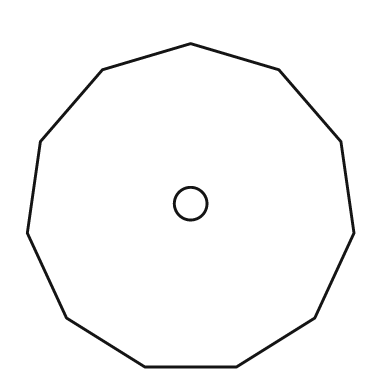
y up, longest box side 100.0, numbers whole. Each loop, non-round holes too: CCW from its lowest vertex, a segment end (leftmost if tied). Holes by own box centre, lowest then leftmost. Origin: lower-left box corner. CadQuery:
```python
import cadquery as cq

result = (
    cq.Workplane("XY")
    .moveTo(36.0, 0.0)
    .lineTo(64.0, 0.0)
    .lineTo(88.0, 15.0)
    .lineTo(100.0, 41.0)
    .lineTo(96.0, 69.0)
    .lineTo(77.0, 91.0)
    .lineTo(50.0, 99.0)
    .lineTo(23.0, 91.0)
    .lineTo(4.0, 69.0)
    .lineTo(0.0, 41.0)
    .lineTo(12.0, 15.0)
    .close()
    .moveTo(50.0, 50.0)
    .circle(5.0)
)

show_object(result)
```